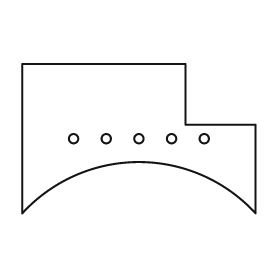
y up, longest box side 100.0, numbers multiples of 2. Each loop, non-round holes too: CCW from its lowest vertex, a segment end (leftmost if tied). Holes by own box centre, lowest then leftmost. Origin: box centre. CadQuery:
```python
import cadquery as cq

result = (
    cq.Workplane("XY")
    .moveTo(-50.0, -32.0)
    .threePointArc((0.0, -10.0), (50.0, -32.0))
    .lineTo(50.0, 6.0)
    .lineTo(20.0, 6.0)
    .lineTo(20.0, 32.0)
    .lineTo(-50.0, 32.0)
    .close()
    .moveTo(-28.0, 0.0)
    .circle(2.0)
    .moveTo(-14.0, 0.0)
    .circle(2.0)
    .moveTo(0.0, 0.0)
    .circle(2.0)
    .moveTo(14.0, 0.0)
    .circle(2.0)
    .moveTo(28.0, 0.0)
    .circle(2.0)
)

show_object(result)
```